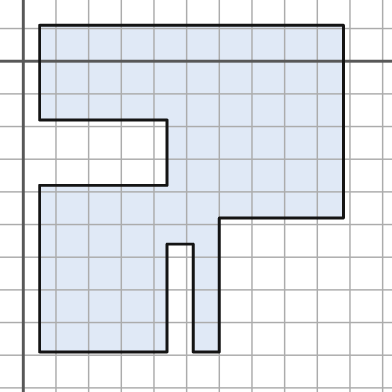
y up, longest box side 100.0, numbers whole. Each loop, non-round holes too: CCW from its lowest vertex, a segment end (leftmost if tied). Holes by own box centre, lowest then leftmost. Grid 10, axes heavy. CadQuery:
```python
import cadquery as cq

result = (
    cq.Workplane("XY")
    .moveTo(5.0, -89.0)
    .lineTo(44.0, -89.0)
    .lineTo(44.0, -56.0)
    .lineTo(52.0, -56.0)
    .lineTo(52.0, -89.0)
    .lineTo(60.0, -89.0)
    .lineTo(60.0, -48.0)
    .lineTo(98.0, -48.0)
    .lineTo(98.0, 11.0)
    .lineTo(5.0, 11.0)
    .lineTo(5.0, -18.0)
    .lineTo(44.0, -18.0)
    .lineTo(44.0, -38.0)
    .lineTo(5.0, -38.0)
    .close()
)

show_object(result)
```